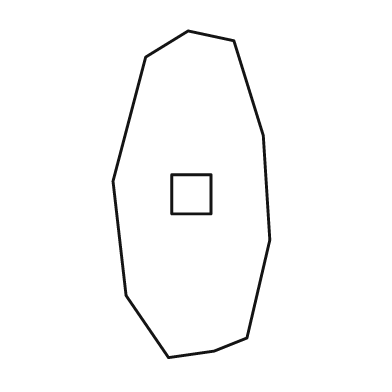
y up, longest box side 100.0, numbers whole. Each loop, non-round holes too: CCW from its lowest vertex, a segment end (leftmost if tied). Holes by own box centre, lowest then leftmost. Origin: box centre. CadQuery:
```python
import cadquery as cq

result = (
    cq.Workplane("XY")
    .moveTo(-7.0, -50.0)
    .lineTo(7.0, -48.0)
    .lineTo(17.0, -44.0)
    .lineTo(24.0, -14.0)
    .lineTo(22.0, 18.0)
    .lineTo(13.0, 47.0)
    .lineTo(-1.0, 50.0)
    .lineTo(-14.0, 42.0)
    .lineTo(-24.0, 4.0)
    .lineTo(-20.0, -31.0)
    .close()
    .moveTo(-6.0, -6.0)
    .lineTo(6.0, -6.0)
    .lineTo(6.0, 6.0)
    .lineTo(-6.0, 6.0)
    .close()
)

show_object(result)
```